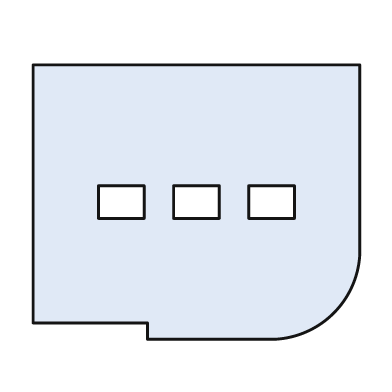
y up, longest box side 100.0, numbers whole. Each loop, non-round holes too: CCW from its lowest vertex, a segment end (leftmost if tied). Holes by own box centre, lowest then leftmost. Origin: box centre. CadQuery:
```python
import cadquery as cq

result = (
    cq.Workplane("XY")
    .moveTo(-15.0, -42.0)
    .lineTo(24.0, -42.0)
    .threePointArc((42.0, -34.0), (50.0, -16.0))
    .lineTo(50.0, 42.0)
    .lineTo(-50.0, 42.0)
    .lineTo(-50.0, -37.0)
    .lineTo(-15.0, -37.0)
    .close()
    .moveTo(-30.0, -5.0)
    .lineTo(-16.0, -5.0)
    .lineTo(-16.0, 5.0)
    .lineTo(-30.0, 5.0)
    .close()
    .moveTo(-7.0, -5.0)
    .lineTo(7.0, -5.0)
    .lineTo(7.0, 5.0)
    .lineTo(-7.0, 5.0)
    .close()
    .moveTo(16.0, -5.0)
    .lineTo(30.0, -5.0)
    .lineTo(30.0, 5.0)
    .lineTo(16.0, 5.0)
    .close()
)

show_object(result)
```